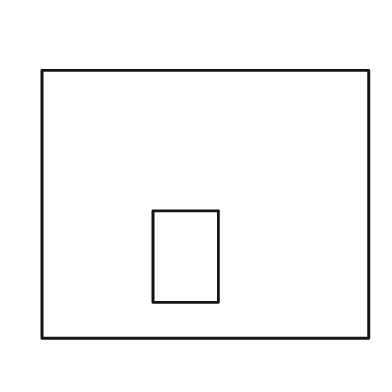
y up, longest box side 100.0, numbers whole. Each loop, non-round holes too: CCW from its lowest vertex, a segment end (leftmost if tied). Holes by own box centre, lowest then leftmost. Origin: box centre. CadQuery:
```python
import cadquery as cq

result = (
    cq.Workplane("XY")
    .moveTo(-50.0, -41.0)
    .lineTo(50.0, -41.0)
    .lineTo(50.0, 41.0)
    .lineTo(-50.0, 41.0)
    .close()
    .moveTo(-16.0, -30.0)
    .lineTo(4.0, -30.0)
    .lineTo(4.0, -2.0)
    .lineTo(-16.0, -2.0)
    .close()
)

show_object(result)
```